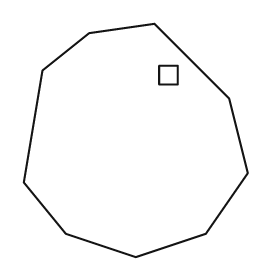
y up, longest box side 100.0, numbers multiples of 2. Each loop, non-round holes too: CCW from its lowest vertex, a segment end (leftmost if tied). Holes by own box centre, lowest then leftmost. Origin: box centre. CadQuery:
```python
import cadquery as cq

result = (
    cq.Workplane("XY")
    .moveTo(0.0, -50.0)
    .lineTo(30.0, -40.0)
    .lineTo(48.0, -14.0)
    .lineTo(40.0, 18.0)
    .lineTo(8.0, 50.0)
    .lineTo(-20.0, 46.0)
    .lineTo(-40.0, 30.0)
    .lineTo(-48.0, -18.0)
    .lineTo(-30.0, -40.0)
    .close()
    .moveTo(10.0, 24.0)
    .lineTo(18.0, 24.0)
    .lineTo(18.0, 32.0)
    .lineTo(10.0, 32.0)
    .close()
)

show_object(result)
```